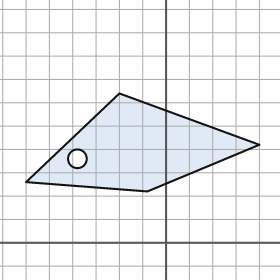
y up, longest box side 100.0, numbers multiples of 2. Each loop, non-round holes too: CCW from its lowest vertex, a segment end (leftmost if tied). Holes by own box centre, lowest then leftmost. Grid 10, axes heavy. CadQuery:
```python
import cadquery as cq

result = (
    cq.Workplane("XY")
    .moveTo(-8.0, 22.0)
    .lineTo(40.0, 42.0)
    .lineTo(-20.0, 64.0)
    .lineTo(-60.0, 26.0)
    .close()
    .moveTo(-38.0, 36.0)
    .circle(4.0)
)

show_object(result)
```